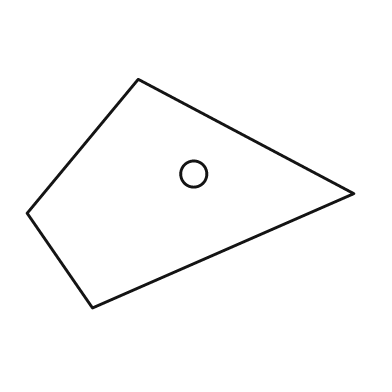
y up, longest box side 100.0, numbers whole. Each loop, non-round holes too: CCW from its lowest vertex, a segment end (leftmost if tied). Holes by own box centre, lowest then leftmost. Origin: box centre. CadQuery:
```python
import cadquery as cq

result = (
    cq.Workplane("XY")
    .moveTo(-30.0, -35.0)
    .lineTo(50.0, 0.0)
    .lineTo(-16.0, 35.0)
    .lineTo(-50.0, -6.0)
    .close()
    .moveTo(1.0, 6.0)
    .circle(4.0)
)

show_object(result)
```